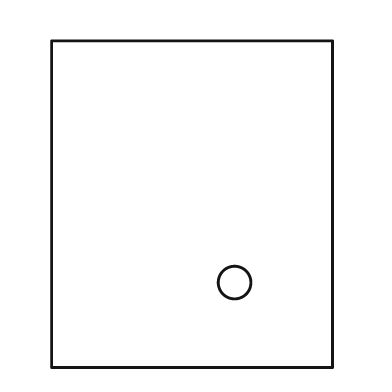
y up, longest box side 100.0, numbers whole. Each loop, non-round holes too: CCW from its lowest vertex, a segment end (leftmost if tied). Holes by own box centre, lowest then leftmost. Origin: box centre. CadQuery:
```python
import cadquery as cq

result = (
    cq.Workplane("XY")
    .moveTo(-43.0, -50.0)
    .lineTo(43.0, -50.0)
    .lineTo(43.0, 50.0)
    .lineTo(-43.0, 50.0)
    .close()
    .moveTo(13.0, -24.0)
    .circle(5.0)
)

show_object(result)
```